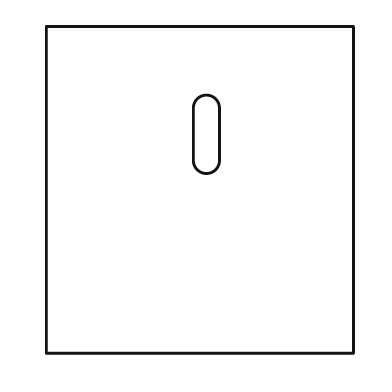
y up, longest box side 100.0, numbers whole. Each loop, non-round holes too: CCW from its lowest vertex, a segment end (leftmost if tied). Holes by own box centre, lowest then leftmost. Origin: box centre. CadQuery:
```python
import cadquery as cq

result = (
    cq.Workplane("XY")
    .moveTo(-47.0, -50.0)
    .lineTo(47.0, -50.0)
    .lineTo(47.0, 50.0)
    .lineTo(-47.0, 50.0)
    .close()
    .moveTo(-2.0, 9.0)
    .threePointArc((2.0, 5.0), (6.0, 9.0))
    .lineTo(6.0, 25.0)
    .threePointArc((2.0, 29.0), (-2.0, 25.0))
    .close()
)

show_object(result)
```